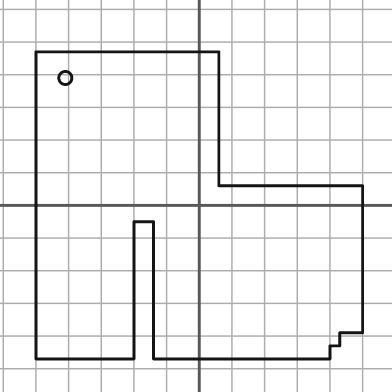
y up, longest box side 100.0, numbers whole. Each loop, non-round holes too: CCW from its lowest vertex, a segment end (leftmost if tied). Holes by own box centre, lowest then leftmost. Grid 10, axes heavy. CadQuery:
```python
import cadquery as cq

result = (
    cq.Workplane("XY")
    .moveTo(-50.0, -47.0)
    .lineTo(-20.0, -47.0)
    .lineTo(-20.0, -5.0)
    .lineTo(-14.0, -5.0)
    .lineTo(-14.0, -47.0)
    .lineTo(40.0, -47.0)
    .lineTo(40.0, -43.0)
    .lineTo(43.0, -43.0)
    .lineTo(43.0, -39.0)
    .lineTo(50.0, -39.0)
    .lineTo(50.0, 6.0)
    .lineTo(6.0, 6.0)
    .lineTo(6.0, 47.0)
    .lineTo(-50.0, 47.0)
    .close()
    .moveTo(-41.0, 39.0)
    .circle(2.0)
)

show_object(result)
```